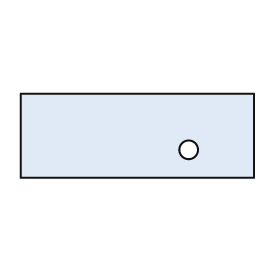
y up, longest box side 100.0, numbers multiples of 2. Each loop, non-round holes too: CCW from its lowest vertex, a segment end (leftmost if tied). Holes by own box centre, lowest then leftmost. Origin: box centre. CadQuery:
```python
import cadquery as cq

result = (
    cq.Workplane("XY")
    .moveTo(-50.0, -18.0)
    .lineTo(50.0, -18.0)
    .lineTo(50.0, 18.0)
    .lineTo(-50.0, 18.0)
    .close()
    .moveTo(22.0, -6.0)
    .circle(4.0)
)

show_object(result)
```